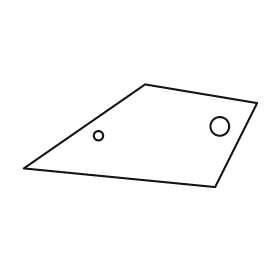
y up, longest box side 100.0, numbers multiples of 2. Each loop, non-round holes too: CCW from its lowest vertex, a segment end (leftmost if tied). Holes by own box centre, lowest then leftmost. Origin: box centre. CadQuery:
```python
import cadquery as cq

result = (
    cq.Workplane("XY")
    .moveTo(32.0, -22.0)
    .lineTo(50.0, 14.0)
    .lineTo(2.0, 22.0)
    .lineTo(-50.0, -14.0)
    .close()
    .moveTo(-18.0, 0.0)
    .circle(2.0)
    .moveTo(34.0, 4.0)
    .circle(4.0)
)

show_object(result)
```